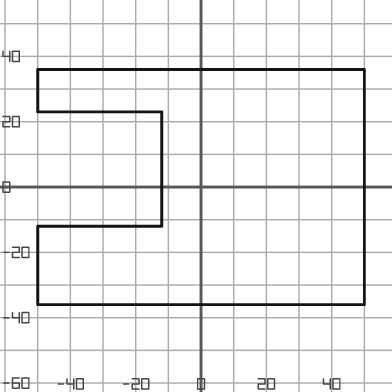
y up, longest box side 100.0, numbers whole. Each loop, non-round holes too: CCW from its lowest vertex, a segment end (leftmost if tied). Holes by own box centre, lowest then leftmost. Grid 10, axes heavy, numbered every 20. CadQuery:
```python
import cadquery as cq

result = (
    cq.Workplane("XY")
    .moveTo(-50.0, -36.0)
    .lineTo(50.0, -36.0)
    .lineTo(50.0, 36.0)
    .lineTo(-50.0, 36.0)
    .lineTo(-50.0, 23.0)
    .lineTo(-12.0, 23.0)
    .lineTo(-12.0, -12.0)
    .lineTo(-50.0, -12.0)
    .close()
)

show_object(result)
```